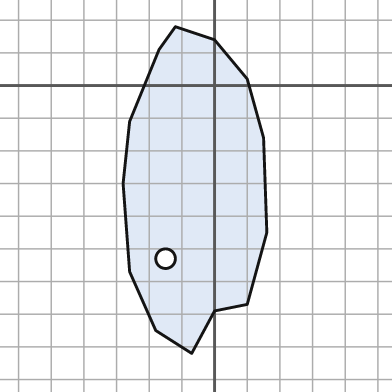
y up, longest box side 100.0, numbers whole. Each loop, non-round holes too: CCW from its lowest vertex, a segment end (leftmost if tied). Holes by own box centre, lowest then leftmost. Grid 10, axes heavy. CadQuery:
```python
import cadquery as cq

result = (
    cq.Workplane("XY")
    .moveTo(-7.0, -82.0)
    .lineTo(0.0, -69.0)
    .lineTo(10.0, -67.0)
    .lineTo(16.0, -45.0)
    .lineTo(15.0, -16.0)
    .lineTo(10.0, 2.0)
    .lineTo(0.0, 14.0)
    .lineTo(-12.0, 18.0)
    .lineTo(-17.0, 11.0)
    .lineTo(-26.0, -11.0)
    .lineTo(-28.0, -30.0)
    .lineTo(-26.0, -57.0)
    .lineTo(-18.0, -75.0)
    .close()
    .moveTo(-15.0, -53.0)
    .circle(3.0)
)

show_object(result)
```